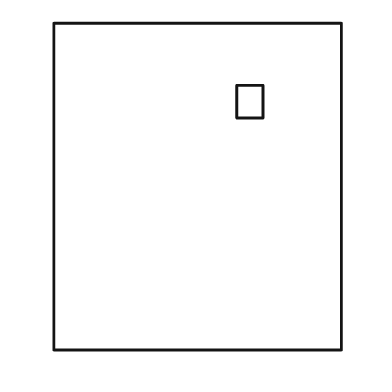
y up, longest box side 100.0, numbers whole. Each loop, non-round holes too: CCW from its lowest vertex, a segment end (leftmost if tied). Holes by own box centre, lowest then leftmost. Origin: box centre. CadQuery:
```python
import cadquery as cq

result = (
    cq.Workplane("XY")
    .moveTo(-44.0, -50.0)
    .lineTo(44.0, -50.0)
    .lineTo(44.0, 50.0)
    .lineTo(-44.0, 50.0)
    .close()
    .moveTo(12.0, 21.0)
    .lineTo(20.0, 21.0)
    .lineTo(20.0, 31.0)
    .lineTo(12.0, 31.0)
    .close()
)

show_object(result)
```